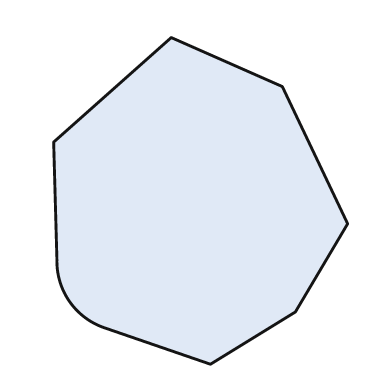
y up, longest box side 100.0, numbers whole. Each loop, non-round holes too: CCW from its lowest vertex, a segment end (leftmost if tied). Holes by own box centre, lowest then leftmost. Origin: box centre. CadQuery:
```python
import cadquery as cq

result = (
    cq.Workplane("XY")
    .moveTo(3.0, -50.0)
    .lineTo(29.0, -34.0)
    .lineTo(45.0, -7.0)
    .lineTo(25.0, 35.0)
    .lineTo(-9.0, 50.0)
    .lineTo(-45.0, 18.0)
    .lineTo(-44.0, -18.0)
    .threePointArc((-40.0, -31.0), (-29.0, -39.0))
    .close()
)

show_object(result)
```